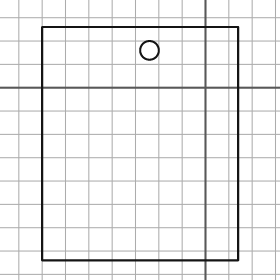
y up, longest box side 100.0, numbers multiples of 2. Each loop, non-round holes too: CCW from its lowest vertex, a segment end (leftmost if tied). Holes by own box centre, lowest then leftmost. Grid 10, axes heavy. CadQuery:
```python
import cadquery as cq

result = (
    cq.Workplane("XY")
    .moveTo(-70.0, -74.0)
    .lineTo(14.0, -74.0)
    .lineTo(14.0, 26.0)
    .lineTo(-70.0, 26.0)
    .close()
    .moveTo(-24.0, 16.0)
    .circle(4.0)
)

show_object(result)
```